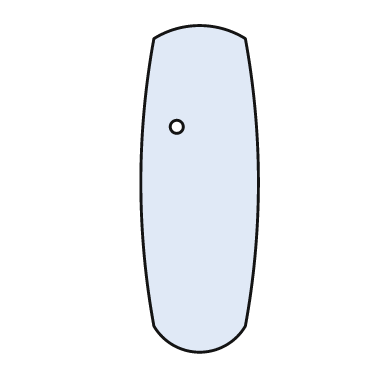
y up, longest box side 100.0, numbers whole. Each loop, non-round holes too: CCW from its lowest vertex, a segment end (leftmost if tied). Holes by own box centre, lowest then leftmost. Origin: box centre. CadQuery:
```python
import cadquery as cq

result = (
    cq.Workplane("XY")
    .moveTo(-14.0, -42.0)
    .threePointArc((0.0, -50.0), (14.0, -42.0))
    .threePointArc((18.0, 2.0), (14.0, 46.0))
    .threePointArc((0.0, 50.0), (-14.0, 46.0))
    .threePointArc((-18.0, 2.0), (-14.0, -42.0))
    .close()
    .moveTo(-7.0, 19.0)
    .circle(2.0)
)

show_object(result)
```